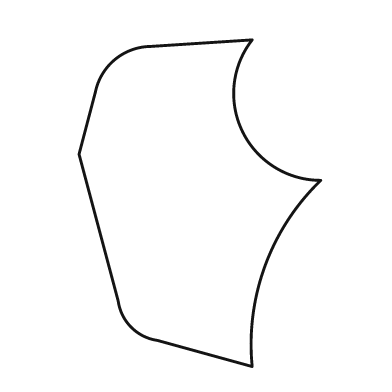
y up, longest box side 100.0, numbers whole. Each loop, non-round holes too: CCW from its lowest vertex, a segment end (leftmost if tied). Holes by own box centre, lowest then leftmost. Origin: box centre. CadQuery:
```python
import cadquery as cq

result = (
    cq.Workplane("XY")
    .moveTo(16.0, -50.0)
    .threePointArc((20.0, -19.0), (37.0, 7.0))
    .threePointArc((13.0, 22.0), (16.0, 50.0))
    .lineTo(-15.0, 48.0)
    .threePointArc((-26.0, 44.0), (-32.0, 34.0))
    .lineTo(-37.0, 15.0)
    .lineTo(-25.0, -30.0)
    .threePointArc((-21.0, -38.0), (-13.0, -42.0))
    .close()
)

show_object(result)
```